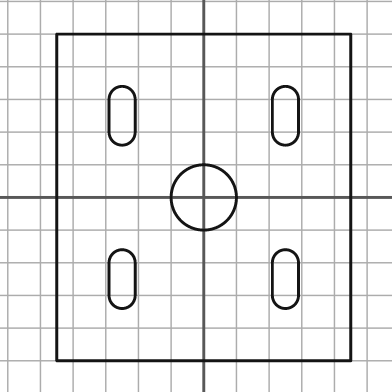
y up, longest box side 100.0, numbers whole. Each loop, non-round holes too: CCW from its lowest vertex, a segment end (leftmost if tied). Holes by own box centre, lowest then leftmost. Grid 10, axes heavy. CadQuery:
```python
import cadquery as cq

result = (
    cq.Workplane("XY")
    .moveTo(-45.0, -50.0)
    .lineTo(45.0, -50.0)
    .lineTo(45.0, 50.0)
    .lineTo(-45.0, 50.0)
    .close()
    .moveTo(-29.0, -30.0)
    .threePointArc((-25.0, -34.0), (-21.0, -30.0))
    .lineTo(-21.0, -20.0)
    .threePointArc((-25.0, -16.0), (-29.0, -20.0))
    .close()
    .moveTo(21.0, -30.0)
    .threePointArc((25.0, -34.0), (29.0, -30.0))
    .lineTo(29.0, -20.0)
    .threePointArc((25.0, -16.0), (21.0, -20.0))
    .close()
    .moveTo(0.0, 0.0)
    .circle(10.0)
    .moveTo(-29.0, 20.0)
    .threePointArc((-25.0, 16.0), (-21.0, 20.0))
    .lineTo(-21.0, 30.0)
    .threePointArc((-25.0, 34.0), (-29.0, 30.0))
    .close()
    .moveTo(21.0, 20.0)
    .threePointArc((25.0, 16.0), (29.0, 20.0))
    .lineTo(29.0, 30.0)
    .threePointArc((25.0, 34.0), (21.0, 30.0))
    .close()
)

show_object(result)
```